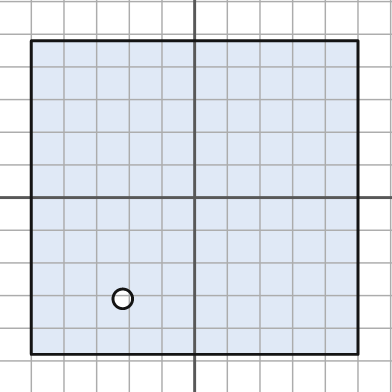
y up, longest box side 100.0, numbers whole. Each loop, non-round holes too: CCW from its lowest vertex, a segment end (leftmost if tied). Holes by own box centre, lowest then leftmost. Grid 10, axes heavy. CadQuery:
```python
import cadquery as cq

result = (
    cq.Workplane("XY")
    .moveTo(-50.0, -48.0)
    .lineTo(50.0, -48.0)
    .lineTo(50.0, 48.0)
    .lineTo(-50.0, 48.0)
    .close()
    .moveTo(-22.0, -31.0)
    .circle(3.0)
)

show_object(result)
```